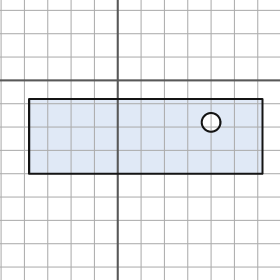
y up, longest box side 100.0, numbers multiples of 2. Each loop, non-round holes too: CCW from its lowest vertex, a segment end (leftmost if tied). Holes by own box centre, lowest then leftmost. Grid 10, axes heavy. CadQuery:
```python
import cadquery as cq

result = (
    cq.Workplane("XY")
    .moveTo(-38.0, -40.0)
    .lineTo(62.0, -40.0)
    .lineTo(62.0, -8.0)
    .lineTo(-38.0, -8.0)
    .close()
    .moveTo(40.0, -18.0)
    .circle(4.0)
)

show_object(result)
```